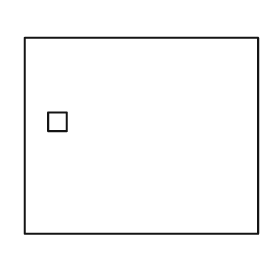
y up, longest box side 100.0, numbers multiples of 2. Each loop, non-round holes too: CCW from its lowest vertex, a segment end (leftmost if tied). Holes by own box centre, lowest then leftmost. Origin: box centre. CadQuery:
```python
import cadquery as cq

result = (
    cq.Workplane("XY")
    .moveTo(-50.0, -42.0)
    .lineTo(50.0, -42.0)
    .lineTo(50.0, 42.0)
    .lineTo(-50.0, 42.0)
    .close()
    .moveTo(-40.0, 2.0)
    .lineTo(-32.0, 2.0)
    .lineTo(-32.0, 10.0)
    .lineTo(-40.0, 10.0)
    .close()
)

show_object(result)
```